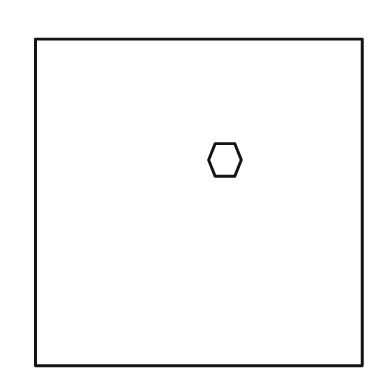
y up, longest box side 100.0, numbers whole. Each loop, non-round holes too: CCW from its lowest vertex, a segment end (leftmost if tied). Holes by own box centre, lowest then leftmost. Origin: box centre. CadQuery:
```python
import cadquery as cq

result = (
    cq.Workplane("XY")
    .moveTo(-50.0, -50.0)
    .lineTo(50.0, -50.0)
    .lineTo(50.0, 50.0)
    .lineTo(-50.0, 50.0)
    .close()
    .moveTo(5.0, 8.0)
    .lineTo(11.0, 8.0)
    .lineTo(13.0, 13.0)
    .lineTo(11.0, 18.0)
    .lineTo(5.0, 18.0)
    .lineTo(3.0, 13.0)
    .close()
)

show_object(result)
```